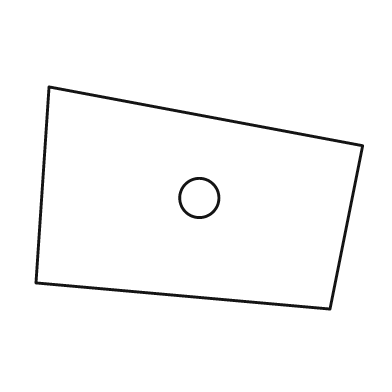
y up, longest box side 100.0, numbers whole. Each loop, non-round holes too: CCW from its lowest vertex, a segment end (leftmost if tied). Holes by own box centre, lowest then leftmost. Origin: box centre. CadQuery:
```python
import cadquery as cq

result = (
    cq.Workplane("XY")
    .moveTo(40.0, -34.0)
    .lineTo(50.0, 16.0)
    .lineTo(-46.0, 34.0)
    .lineTo(-50.0, -26.0)
    .close()
    .moveTo(0.0, 0.0)
    .circle(6.0)
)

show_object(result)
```